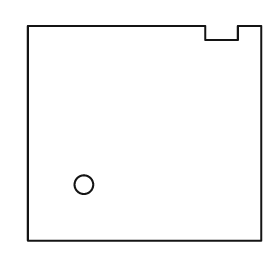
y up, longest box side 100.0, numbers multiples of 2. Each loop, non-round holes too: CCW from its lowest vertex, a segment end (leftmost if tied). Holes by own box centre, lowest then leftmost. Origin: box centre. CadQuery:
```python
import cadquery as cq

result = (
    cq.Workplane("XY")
    .moveTo(-50.0, -46.0)
    .lineTo(50.0, -46.0)
    .lineTo(50.0, 46.0)
    .lineTo(40.0, 46.0)
    .lineTo(40.0, 40.0)
    .lineTo(26.0, 40.0)
    .lineTo(26.0, 46.0)
    .lineTo(-50.0, 46.0)
    .close()
    .moveTo(-26.0, -22.0)
    .circle(4.0)
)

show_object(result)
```